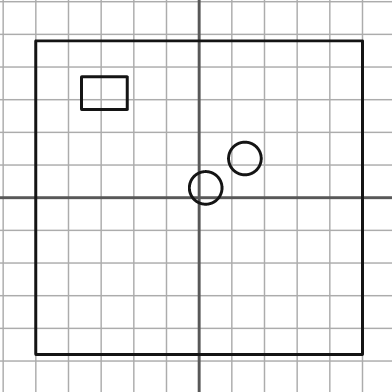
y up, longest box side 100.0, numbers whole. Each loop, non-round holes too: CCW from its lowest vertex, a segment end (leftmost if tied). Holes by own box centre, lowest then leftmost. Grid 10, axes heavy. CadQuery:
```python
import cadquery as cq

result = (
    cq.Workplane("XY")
    .moveTo(-50.0, -48.0)
    .lineTo(50.0, -48.0)
    .lineTo(50.0, 48.0)
    .lineTo(-50.0, 48.0)
    .close()
    .moveTo(2.0, 3.0)
    .circle(5.0)
    .moveTo(14.0, 12.0)
    .circle(5.0)
    .moveTo(-36.0, 27.0)
    .lineTo(-22.0, 27.0)
    .lineTo(-22.0, 37.0)
    .lineTo(-36.0, 37.0)
    .close()
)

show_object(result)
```